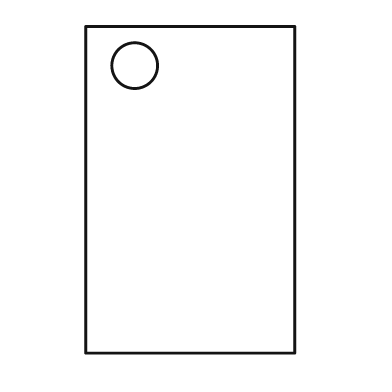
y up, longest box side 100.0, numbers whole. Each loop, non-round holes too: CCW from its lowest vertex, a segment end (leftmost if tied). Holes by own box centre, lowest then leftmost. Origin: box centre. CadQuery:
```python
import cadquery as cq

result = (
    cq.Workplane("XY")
    .moveTo(-32.0, -50.0)
    .lineTo(32.0, -50.0)
    .lineTo(32.0, 50.0)
    .lineTo(-32.0, 50.0)
    .close()
    .moveTo(-17.0, 38.0)
    .circle(7.0)
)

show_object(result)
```